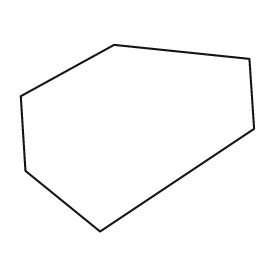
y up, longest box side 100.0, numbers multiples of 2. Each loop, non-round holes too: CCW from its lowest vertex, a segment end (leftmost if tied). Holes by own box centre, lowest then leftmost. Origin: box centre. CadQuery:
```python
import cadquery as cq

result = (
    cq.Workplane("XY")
    .moveTo(-16.0, -40.0)
    .lineTo(50.0, 4.0)
    .lineTo(48.0, 34.0)
    .lineTo(-10.0, 40.0)
    .lineTo(-50.0, 18.0)
    .lineTo(-48.0, -14.0)
    .close()
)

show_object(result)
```